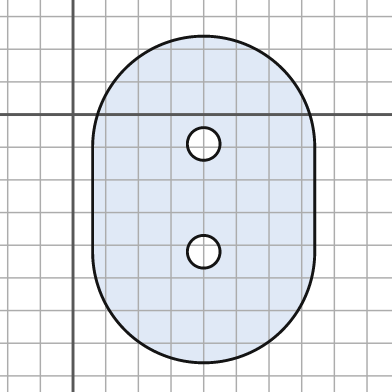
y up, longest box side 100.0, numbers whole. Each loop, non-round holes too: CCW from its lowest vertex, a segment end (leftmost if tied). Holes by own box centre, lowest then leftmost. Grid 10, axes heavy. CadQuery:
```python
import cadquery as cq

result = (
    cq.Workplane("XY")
    .moveTo(6.0, -42.0)
    .threePointArc((40.0, -76.0), (74.0, -42.0))
    .lineTo(74.0, -10.0)
    .threePointArc((40.0, 24.0), (6.0, -10.0))
    .close()
    .moveTo(40.0, -42.0)
    .circle(5.0)
    .moveTo(40.0, -9.0)
    .circle(5.0)
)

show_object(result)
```